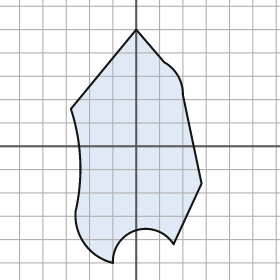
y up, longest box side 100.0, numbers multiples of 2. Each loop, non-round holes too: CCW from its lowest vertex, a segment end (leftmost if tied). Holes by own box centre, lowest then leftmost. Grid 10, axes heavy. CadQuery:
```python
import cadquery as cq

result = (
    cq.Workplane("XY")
    .moveTo(-10.0, -50.0)
    .threePointArc((0.0, -36.0), (16.0, -42.0))
    .lineTo(28.0, -16.0)
    .lineTo(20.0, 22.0)
    .threePointArc((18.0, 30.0), (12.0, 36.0))
    .lineTo(0.0, 50.0)
    .lineTo(-28.0, 16.0)
    .threePointArc((-24.0, -6.0), (-26.0, -28.0))
    .threePointArc((-22.0, -42.0), (-10.0, -50.0))
    .close()
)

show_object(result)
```